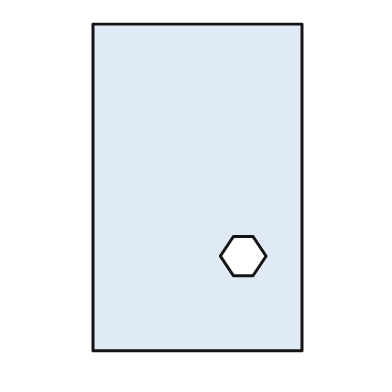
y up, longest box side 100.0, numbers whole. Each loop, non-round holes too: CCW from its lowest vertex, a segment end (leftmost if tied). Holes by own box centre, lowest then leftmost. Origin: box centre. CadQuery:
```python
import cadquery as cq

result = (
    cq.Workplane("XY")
    .moveTo(-32.0, -50.0)
    .lineTo(32.0, -50.0)
    .lineTo(32.0, 50.0)
    .lineTo(-32.0, 50.0)
    .close()
    .moveTo(11.0, -27.0)
    .lineTo(17.0, -27.0)
    .lineTo(21.0, -21.0)
    .lineTo(17.0, -15.0)
    .lineTo(11.0, -15.0)
    .lineTo(7.0, -21.0)
    .close()
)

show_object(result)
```